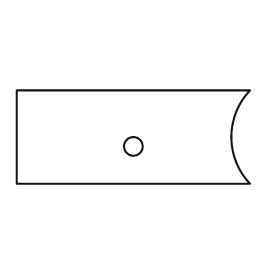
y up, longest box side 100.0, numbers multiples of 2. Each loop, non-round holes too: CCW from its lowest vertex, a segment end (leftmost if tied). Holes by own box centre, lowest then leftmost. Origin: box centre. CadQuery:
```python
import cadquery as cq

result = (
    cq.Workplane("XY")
    .moveTo(-50.0, -20.0)
    .lineTo(50.0, -20.0)
    .threePointArc((42.0, 0.0), (50.0, 20.0))
    .lineTo(-50.0, 20.0)
    .close()
    .moveTo(0.0, -4.0)
    .circle(4.0)
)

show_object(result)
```